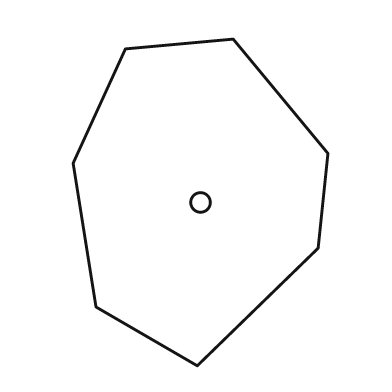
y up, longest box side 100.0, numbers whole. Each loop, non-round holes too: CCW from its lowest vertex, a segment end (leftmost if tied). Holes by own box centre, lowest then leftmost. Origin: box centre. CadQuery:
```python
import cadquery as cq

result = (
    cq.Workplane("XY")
    .moveTo(-1.0, -50.0)
    .lineTo(36.0, -14.0)
    .lineTo(39.0, 15.0)
    .lineTo(10.0, 50.0)
    .lineTo(-23.0, 47.0)
    .lineTo(-39.0, 12.0)
    .lineTo(-32.0, -32.0)
    .close()
    .moveTo(0.0, 0.0)
    .circle(3.0)
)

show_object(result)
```